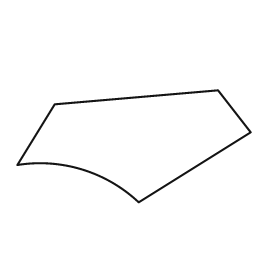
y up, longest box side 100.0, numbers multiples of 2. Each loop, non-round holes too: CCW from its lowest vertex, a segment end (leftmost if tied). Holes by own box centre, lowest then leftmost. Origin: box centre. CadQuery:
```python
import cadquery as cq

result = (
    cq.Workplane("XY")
    .moveTo(2.0, -24.0)
    .lineTo(50.0, 6.0)
    .lineTo(36.0, 24.0)
    .lineTo(-34.0, 18.0)
    .lineTo(-50.0, -8.0)
    .threePointArc((-22.0, -10.0), (2.0, -24.0))
    .close()
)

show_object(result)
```